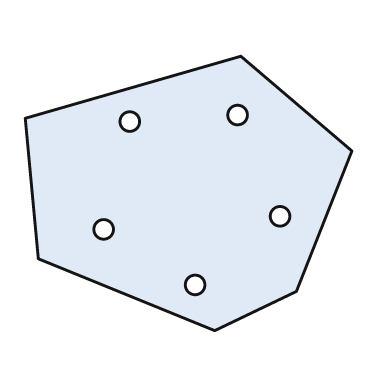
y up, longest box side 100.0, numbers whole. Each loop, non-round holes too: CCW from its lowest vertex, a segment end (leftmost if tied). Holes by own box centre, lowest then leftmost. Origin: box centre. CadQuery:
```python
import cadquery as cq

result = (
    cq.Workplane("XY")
    .moveTo(8.0, -42.0)
    .lineTo(33.0, -30.0)
    .lineTo(50.0, 13.0)
    .lineTo(16.0, 42.0)
    .lineTo(-50.0, 23.0)
    .lineTo(-46.0, -20.0)
    .close()
    .moveTo(2.0, -28.0)
    .circle(3.0)
    .moveTo(-26.0, -11.0)
    .circle(3.0)
    .moveTo(28.0, -7.0)
    .circle(3.0)
    .moveTo(-18.0, 22.0)
    .circle(3.0)
    .moveTo(15.0, 24.0)
    .circle(3.0)
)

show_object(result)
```